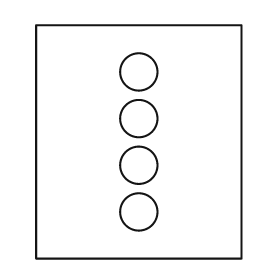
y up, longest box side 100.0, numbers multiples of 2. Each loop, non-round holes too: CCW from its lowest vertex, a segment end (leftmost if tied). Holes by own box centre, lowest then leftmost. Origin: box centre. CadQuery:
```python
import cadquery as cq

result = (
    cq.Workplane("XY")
    .moveTo(-44.0, -50.0)
    .lineTo(44.0, -50.0)
    .lineTo(44.0, 50.0)
    .lineTo(-44.0, 50.0)
    .close()
    .moveTo(0.0, -30.0)
    .circle(8.0)
    .moveTo(0.0, -10.0)
    .circle(8.0)
    .moveTo(0.0, 10.0)
    .circle(8.0)
    .moveTo(0.0, 30.0)
    .circle(8.0)
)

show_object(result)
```